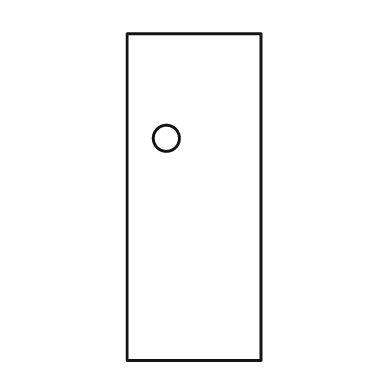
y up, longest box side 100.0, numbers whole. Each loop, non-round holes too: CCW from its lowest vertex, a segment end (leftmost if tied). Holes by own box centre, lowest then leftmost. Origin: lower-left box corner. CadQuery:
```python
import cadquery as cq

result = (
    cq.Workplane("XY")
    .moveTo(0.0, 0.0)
    .lineTo(41.0, 0.0)
    .lineTo(41.0, 100.0)
    .lineTo(0.0, 100.0)
    .close()
    .moveTo(12.0, 68.0)
    .circle(4.0)
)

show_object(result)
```